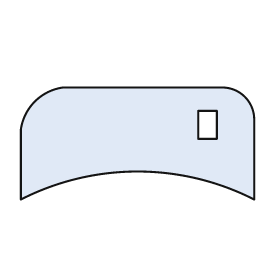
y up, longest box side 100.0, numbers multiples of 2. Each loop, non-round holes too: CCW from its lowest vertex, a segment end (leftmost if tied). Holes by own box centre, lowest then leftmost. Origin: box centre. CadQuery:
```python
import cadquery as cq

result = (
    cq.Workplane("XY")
    .moveTo(-50.0, -24.0)
    .threePointArc((0.0, -12.0), (50.0, -24.0))
    .lineTo(50.0, 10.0)
    .threePointArc((46.0, 20.0), (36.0, 24.0))
    .lineTo(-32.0, 24.0)
    .threePointArc((-44.0, 18.0), (-50.0, 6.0))
    .close()
    .moveTo(26.0, 2.0)
    .lineTo(34.0, 2.0)
    .lineTo(34.0, 14.0)
    .lineTo(26.0, 14.0)
    .close()
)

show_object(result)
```